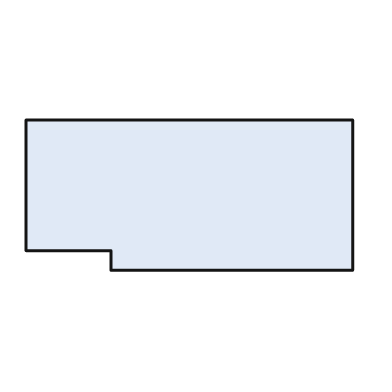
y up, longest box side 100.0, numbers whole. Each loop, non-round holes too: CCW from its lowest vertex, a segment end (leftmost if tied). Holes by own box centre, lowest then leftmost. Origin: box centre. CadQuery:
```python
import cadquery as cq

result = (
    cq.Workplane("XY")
    .moveTo(-24.0, -23.0)
    .lineTo(50.0, -23.0)
    .lineTo(50.0, 23.0)
    .lineTo(-50.0, 23.0)
    .lineTo(-50.0, -17.0)
    .lineTo(-24.0, -17.0)
    .close()
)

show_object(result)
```